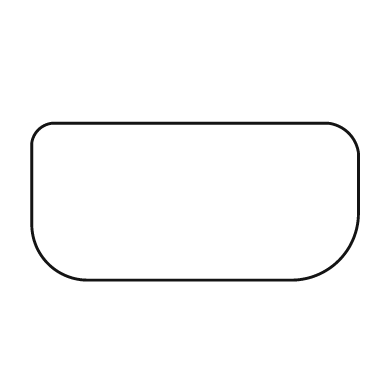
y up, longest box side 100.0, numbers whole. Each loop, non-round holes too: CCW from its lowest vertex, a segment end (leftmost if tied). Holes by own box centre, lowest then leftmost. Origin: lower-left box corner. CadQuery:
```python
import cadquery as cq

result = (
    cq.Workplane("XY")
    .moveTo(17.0, 0.0)
    .lineTo(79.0, 0.0)
    .threePointArc((94.0, 6.0), (100.0, 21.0))
    .lineTo(100.0, 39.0)
    .threePointArc((97.0, 45.0), (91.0, 48.0))
    .lineTo(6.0, 48.0)
    .threePointArc((2.0, 46.0), (0.0, 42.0))
    .lineTo(0.0, 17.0)
    .threePointArc((5.0, 5.0), (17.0, 0.0))
    .close()
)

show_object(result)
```